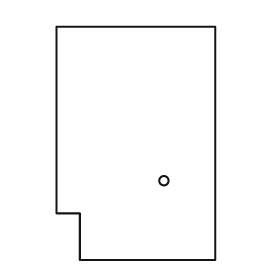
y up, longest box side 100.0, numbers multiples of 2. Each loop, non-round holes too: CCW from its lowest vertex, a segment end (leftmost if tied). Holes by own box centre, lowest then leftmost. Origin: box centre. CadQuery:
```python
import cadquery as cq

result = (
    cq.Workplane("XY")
    .moveTo(-24.0, -50.0)
    .lineTo(34.0, -50.0)
    .lineTo(34.0, 50.0)
    .lineTo(-34.0, 50.0)
    .lineTo(-34.0, -30.0)
    .lineTo(-24.0, -30.0)
    .close()
    .moveTo(12.0, -16.0)
    .circle(2.0)
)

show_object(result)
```